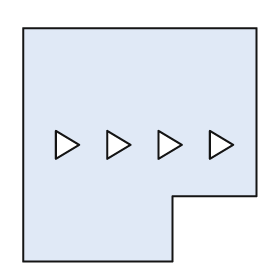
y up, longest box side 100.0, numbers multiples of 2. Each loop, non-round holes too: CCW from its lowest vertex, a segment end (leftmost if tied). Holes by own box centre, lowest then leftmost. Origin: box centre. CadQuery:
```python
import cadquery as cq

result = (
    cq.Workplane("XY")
    .moveTo(-50.0, -50.0)
    .lineTo(14.0, -50.0)
    .lineTo(14.0, -22.0)
    .lineTo(50.0, -22.0)
    .lineTo(50.0, 50.0)
    .lineTo(-50.0, 50.0)
    .close()
    .moveTo(-36.0, -6.0)
    .lineTo(-26.0, 0.0)
    .lineTo(-36.0, 6.0)
    .close()
    .moveTo(-14.0, -6.0)
    .lineTo(-4.0, 0.0)
    .lineTo(-14.0, 6.0)
    .close()
    .moveTo(8.0, -6.0)
    .lineTo(18.0, 0.0)
    .lineTo(8.0, 6.0)
    .close()
    .moveTo(30.0, -6.0)
    .lineTo(40.0, 0.0)
    .lineTo(30.0, 6.0)
    .close()
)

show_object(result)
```